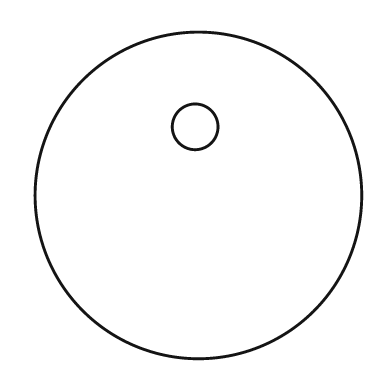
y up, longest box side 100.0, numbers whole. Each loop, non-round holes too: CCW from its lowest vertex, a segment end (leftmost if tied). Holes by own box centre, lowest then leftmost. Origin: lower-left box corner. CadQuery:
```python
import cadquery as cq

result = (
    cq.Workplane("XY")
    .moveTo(50.0, 50.0)
    .circle(50.0)
    .moveTo(49.0, 71.0)
    .circle(7.0)
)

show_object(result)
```